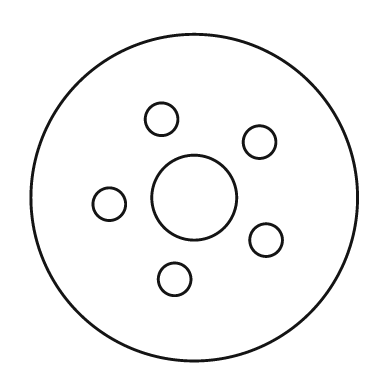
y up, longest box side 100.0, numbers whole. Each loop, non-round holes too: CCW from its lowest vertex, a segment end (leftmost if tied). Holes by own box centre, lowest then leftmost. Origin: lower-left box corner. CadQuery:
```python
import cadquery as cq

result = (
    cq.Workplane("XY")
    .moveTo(50.0, 50.0)
    .circle(50.0)
    .moveTo(44.0, 25.0)
    .circle(5.0)
    .moveTo(72.0, 37.0)
    .circle(5.0)
    .moveTo(24.0, 48.0)
    .circle(5.0)
    .moveTo(50.0, 50.0)
    .circle(13.0)
    .moveTo(70.0, 67.0)
    .circle(5.0)
    .moveTo(40.0, 74.0)
    .circle(5.0)
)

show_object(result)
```